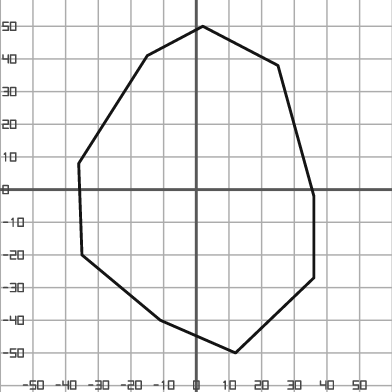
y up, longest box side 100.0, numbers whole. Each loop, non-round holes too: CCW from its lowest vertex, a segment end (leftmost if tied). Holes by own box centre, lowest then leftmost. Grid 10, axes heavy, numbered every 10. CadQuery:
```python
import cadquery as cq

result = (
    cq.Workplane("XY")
    .moveTo(12.0, -50.0)
    .lineTo(36.0, -27.0)
    .lineTo(36.0, -2.0)
    .lineTo(25.0, 38.0)
    .lineTo(2.0, 50.0)
    .lineTo(-15.0, 41.0)
    .lineTo(-36.0, 8.0)
    .lineTo(-35.0, -20.0)
    .lineTo(-11.0, -40.0)
    .close()
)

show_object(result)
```